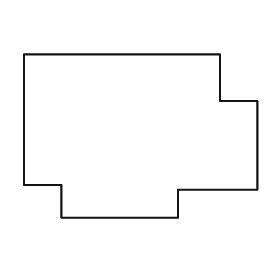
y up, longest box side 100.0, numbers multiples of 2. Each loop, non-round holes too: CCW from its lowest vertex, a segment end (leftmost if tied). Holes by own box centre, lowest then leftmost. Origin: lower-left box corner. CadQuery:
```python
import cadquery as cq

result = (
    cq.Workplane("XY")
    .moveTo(16.0, 0.0)
    .lineTo(66.0, 0.0)
    .lineTo(66.0, 12.0)
    .lineTo(100.0, 12.0)
    .lineTo(100.0, 50.0)
    .lineTo(84.0, 50.0)
    .lineTo(84.0, 70.0)
    .lineTo(0.0, 70.0)
    .lineTo(0.0, 14.0)
    .lineTo(16.0, 14.0)
    .close()
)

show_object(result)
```